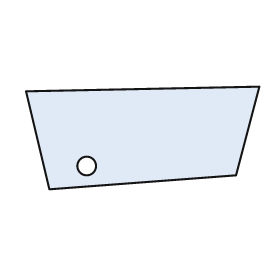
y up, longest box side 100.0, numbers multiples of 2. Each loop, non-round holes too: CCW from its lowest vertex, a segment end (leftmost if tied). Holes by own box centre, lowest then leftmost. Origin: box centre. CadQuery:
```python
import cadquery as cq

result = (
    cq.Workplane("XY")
    .moveTo(-40.0, -22.0)
    .lineTo(40.0, -16.0)
    .lineTo(50.0, 22.0)
    .lineTo(-50.0, 20.0)
    .close()
    .moveTo(-24.0, -12.0)
    .circle(4.0)
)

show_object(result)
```